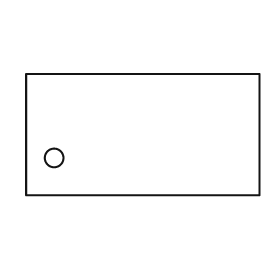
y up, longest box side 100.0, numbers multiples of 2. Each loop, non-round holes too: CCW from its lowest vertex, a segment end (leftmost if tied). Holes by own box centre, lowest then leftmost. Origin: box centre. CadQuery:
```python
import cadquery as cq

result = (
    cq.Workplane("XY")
    .moveTo(-50.0, -26.0)
    .lineTo(50.0, -26.0)
    .lineTo(50.0, 26.0)
    .lineTo(-50.0, 26.0)
    .close()
    .moveTo(-38.0, -10.0)
    .circle(4.0)
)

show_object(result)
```